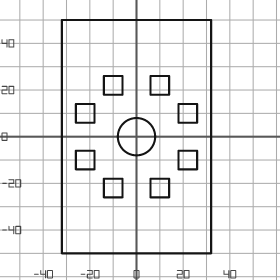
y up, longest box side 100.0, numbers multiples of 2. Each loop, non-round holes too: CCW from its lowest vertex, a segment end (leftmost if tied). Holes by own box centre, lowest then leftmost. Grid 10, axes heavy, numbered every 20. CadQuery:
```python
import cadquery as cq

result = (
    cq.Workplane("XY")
    .moveTo(-32.0, -50.0)
    .lineTo(32.0, -50.0)
    .lineTo(32.0, 50.0)
    .lineTo(-32.0, 50.0)
    .close()
    .moveTo(-14.0, -26.0)
    .lineTo(-6.0, -26.0)
    .lineTo(-6.0, -18.0)
    .lineTo(-14.0, -18.0)
    .close()
    .moveTo(6.0, -26.0)
    .lineTo(14.0, -26.0)
    .lineTo(14.0, -18.0)
    .lineTo(6.0, -18.0)
    .close()
    .moveTo(-26.0, -14.0)
    .lineTo(-18.0, -14.0)
    .lineTo(-18.0, -6.0)
    .lineTo(-26.0, -6.0)
    .close()
    .moveTo(18.0, -14.0)
    .lineTo(26.0, -14.0)
    .lineTo(26.0, -6.0)
    .lineTo(18.0, -6.0)
    .close()
    .moveTo(0.0, 0.0)
    .circle(8.0)
    .moveTo(-26.0, 6.0)
    .lineTo(-18.0, 6.0)
    .lineTo(-18.0, 14.0)
    .lineTo(-26.0, 14.0)
    .close()
    .moveTo(18.0, 6.0)
    .lineTo(26.0, 6.0)
    .lineTo(26.0, 14.0)
    .lineTo(18.0, 14.0)
    .close()
    .moveTo(-14.0, 18.0)
    .lineTo(-6.0, 18.0)
    .lineTo(-6.0, 26.0)
    .lineTo(-14.0, 26.0)
    .close()
    .moveTo(6.0, 18.0)
    .lineTo(14.0, 18.0)
    .lineTo(14.0, 26.0)
    .lineTo(6.0, 26.0)
    .close()
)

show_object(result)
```